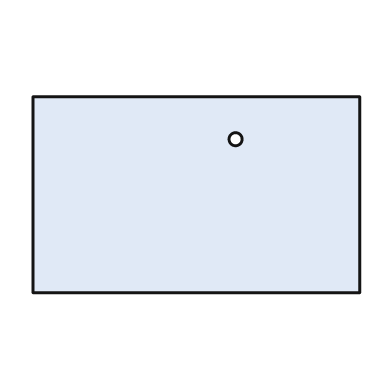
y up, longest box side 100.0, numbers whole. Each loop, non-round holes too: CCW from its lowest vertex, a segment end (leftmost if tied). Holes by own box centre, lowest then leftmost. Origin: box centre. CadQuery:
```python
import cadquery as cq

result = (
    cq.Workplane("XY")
    .moveTo(-50.0, -30.0)
    .lineTo(50.0, -30.0)
    .lineTo(50.0, 30.0)
    .lineTo(-50.0, 30.0)
    .close()
    .moveTo(12.0, 17.0)
    .circle(2.0)
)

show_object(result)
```